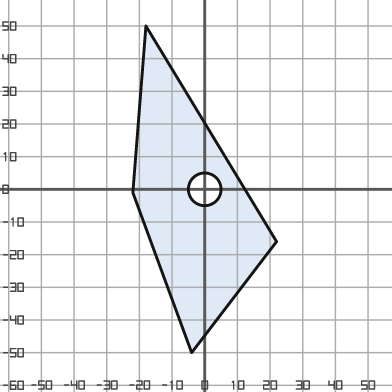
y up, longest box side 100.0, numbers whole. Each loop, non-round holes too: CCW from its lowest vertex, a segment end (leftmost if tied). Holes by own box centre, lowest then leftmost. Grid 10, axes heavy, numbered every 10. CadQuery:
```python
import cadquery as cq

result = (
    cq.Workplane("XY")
    .moveTo(-4.0, -50.0)
    .lineTo(22.0, -16.0)
    .lineTo(-18.0, 50.0)
    .lineTo(-22.0, -1.0)
    .close()
    .moveTo(0.0, 0.0)
    .circle(5.0)
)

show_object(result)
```